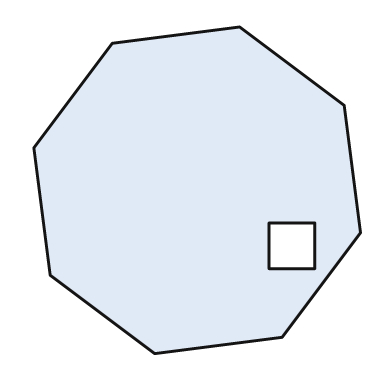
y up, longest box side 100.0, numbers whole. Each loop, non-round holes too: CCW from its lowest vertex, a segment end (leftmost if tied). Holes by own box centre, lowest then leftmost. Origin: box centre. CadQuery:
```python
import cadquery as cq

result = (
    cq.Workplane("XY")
    .moveTo(-13.0, -50.0)
    .lineTo(26.0, -45.0)
    .lineTo(50.0, -13.0)
    .lineTo(45.0, 26.0)
    .lineTo(13.0, 50.0)
    .lineTo(-26.0, 45.0)
    .lineTo(-50.0, 13.0)
    .lineTo(-45.0, -26.0)
    .close()
    .moveTo(22.0, -24.0)
    .lineTo(36.0, -24.0)
    .lineTo(36.0, -10.0)
    .lineTo(22.0, -10.0)
    .close()
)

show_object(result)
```